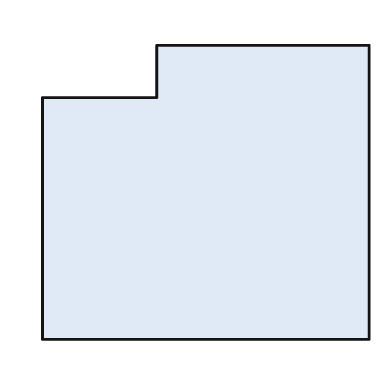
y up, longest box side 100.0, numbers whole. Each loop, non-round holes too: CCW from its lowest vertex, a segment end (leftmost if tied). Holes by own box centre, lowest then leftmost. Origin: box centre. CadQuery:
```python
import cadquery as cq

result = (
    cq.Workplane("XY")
    .moveTo(-50.0, -45.0)
    .lineTo(50.0, -45.0)
    .lineTo(50.0, 45.0)
    .lineTo(-15.0, 45.0)
    .lineTo(-15.0, 29.0)
    .lineTo(-50.0, 29.0)
    .close()
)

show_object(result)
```